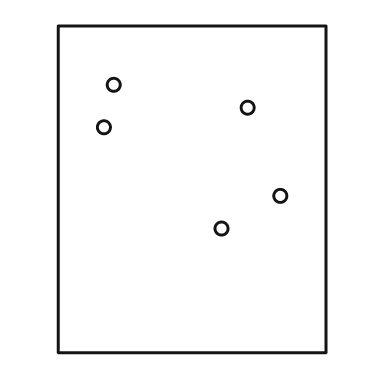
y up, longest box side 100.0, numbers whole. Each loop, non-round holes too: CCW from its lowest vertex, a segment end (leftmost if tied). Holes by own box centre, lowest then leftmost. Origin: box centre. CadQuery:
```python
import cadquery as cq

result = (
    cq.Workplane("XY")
    .moveTo(-41.0, -50.0)
    .lineTo(41.0, -50.0)
    .lineTo(41.0, 50.0)
    .lineTo(-41.0, 50.0)
    .close()
    .moveTo(9.0, -12.0)
    .circle(2.0)
    .moveTo(27.0, -2.0)
    .circle(2.0)
    .moveTo(-27.0, 19.0)
    .circle(2.0)
    .moveTo(17.0, 25.0)
    .circle(2.0)
    .moveTo(-24.0, 32.0)
    .circle(2.0)
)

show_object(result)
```